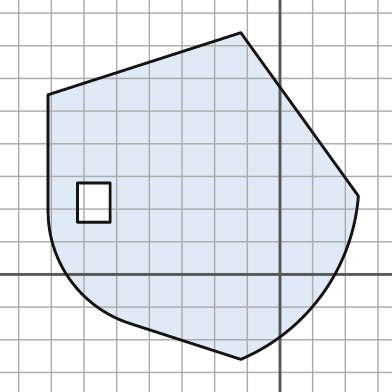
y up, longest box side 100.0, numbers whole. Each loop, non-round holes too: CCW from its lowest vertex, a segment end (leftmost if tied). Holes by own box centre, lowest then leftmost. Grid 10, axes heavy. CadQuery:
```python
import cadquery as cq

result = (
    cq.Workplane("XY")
    .moveTo(-12.0, -26.0)
    .threePointArc((13.0, -6.0), (24.0, 24.0))
    .lineTo(-12.0, 74.0)
    .lineTo(-71.0, 55.0)
    .lineTo(-71.0, 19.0)
    .threePointArc((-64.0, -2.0), (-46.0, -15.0))
    .close()
    .moveTo(-62.0, 16.0)
    .lineTo(-52.0, 16.0)
    .lineTo(-52.0, 28.0)
    .lineTo(-62.0, 28.0)
    .close()
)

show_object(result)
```